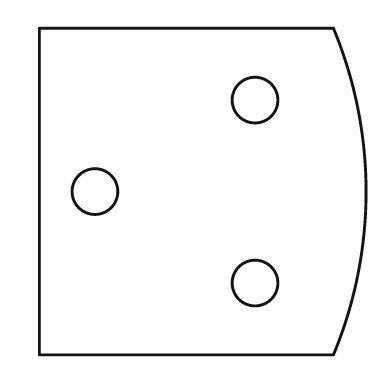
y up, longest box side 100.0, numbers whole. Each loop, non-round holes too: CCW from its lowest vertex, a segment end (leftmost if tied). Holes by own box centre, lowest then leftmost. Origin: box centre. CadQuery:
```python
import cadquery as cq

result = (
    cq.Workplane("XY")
    .moveTo(-50.0, -50.0)
    .lineTo(40.0, -50.0)
    .threePointArc((50.0, 0.0), (40.0, 50.0))
    .lineTo(-50.0, 50.0)
    .close()
    .moveTo(16.0, -28.0)
    .circle(7.0)
    .moveTo(-33.0, 0.0)
    .circle(7.0)
    .moveTo(16.0, 28.0)
    .circle(7.0)
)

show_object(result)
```